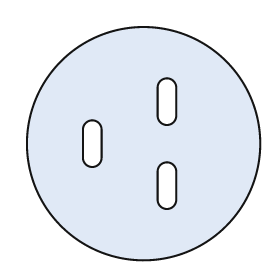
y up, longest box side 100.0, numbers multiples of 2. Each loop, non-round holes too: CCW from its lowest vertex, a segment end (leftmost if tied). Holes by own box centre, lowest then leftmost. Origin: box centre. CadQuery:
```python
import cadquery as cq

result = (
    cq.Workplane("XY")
    .moveTo(0.0, 0.0)
    .circle(50.0)
    .moveTo(6.0, -24.0)
    .threePointArc((10.0, -28.0), (14.0, -24.0))
    .lineTo(14.0, -12.0)
    .threePointArc((10.0, -8.0), (6.0, -12.0))
    .close()
    .moveTo(-26.0, -6.0)
    .threePointArc((-22.0, -10.0), (-18.0, -6.0))
    .lineTo(-18.0, 6.0)
    .threePointArc((-22.0, 10.0), (-26.0, 6.0))
    .close()
    .moveTo(6.0, 12.0)
    .threePointArc((10.0, 8.0), (14.0, 12.0))
    .lineTo(14.0, 24.0)
    .threePointArc((10.0, 28.0), (6.0, 24.0))
    .close()
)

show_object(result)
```